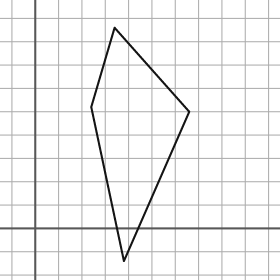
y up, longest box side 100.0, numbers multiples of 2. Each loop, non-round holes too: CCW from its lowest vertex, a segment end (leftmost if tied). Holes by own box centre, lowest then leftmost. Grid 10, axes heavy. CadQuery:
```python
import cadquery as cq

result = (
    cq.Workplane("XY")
    .moveTo(38.0, -14.0)
    .lineTo(66.0, 50.0)
    .lineTo(34.0, 86.0)
    .lineTo(24.0, 52.0)
    .close()
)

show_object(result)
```